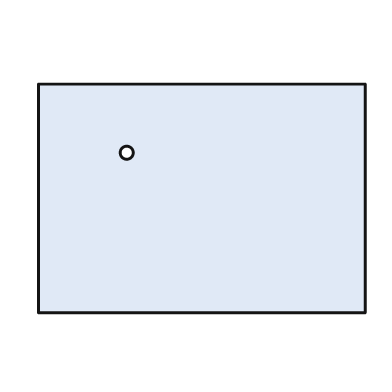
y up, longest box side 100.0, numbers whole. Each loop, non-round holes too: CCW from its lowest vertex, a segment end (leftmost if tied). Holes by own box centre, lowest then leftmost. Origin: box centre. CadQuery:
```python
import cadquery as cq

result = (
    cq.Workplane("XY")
    .moveTo(-50.0, -35.0)
    .lineTo(50.0, -35.0)
    .lineTo(50.0, 35.0)
    .lineTo(-50.0, 35.0)
    .close()
    .moveTo(-23.0, 14.0)
    .circle(2.0)
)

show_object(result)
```